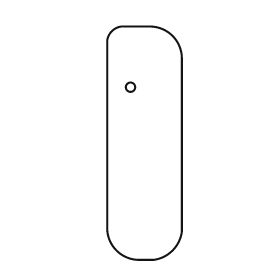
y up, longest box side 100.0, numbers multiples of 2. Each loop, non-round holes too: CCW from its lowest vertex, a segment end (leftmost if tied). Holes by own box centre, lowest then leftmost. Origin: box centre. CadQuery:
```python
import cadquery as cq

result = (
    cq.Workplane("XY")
    .moveTo(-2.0, -50.0)
    .lineTo(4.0, -50.0)
    .threePointArc((12.0, -46.0), (16.0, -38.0))
    .lineTo(16.0, 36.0)
    .threePointArc((12.0, 46.0), (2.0, 50.0))
    .lineTo(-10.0, 50.0)
    .threePointArc((-14.0, 48.0), (-16.0, 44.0))
    .lineTo(-16.0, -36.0)
    .threePointArc((-12.0, -46.0), (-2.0, -50.0))
    .close()
    .moveTo(-6.0, 24.0)
    .circle(2.0)
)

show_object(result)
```